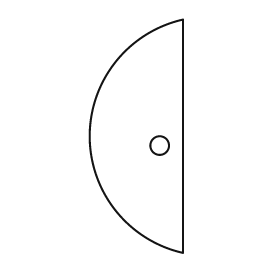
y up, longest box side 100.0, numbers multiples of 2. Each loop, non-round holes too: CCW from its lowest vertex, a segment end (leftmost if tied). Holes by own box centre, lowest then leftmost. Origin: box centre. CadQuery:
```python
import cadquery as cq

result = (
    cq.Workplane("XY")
    .moveTo(20.0, -50.0)
    .lineTo(20.0, 50.0)
    .threePointArc((-20.0, 0.0), (20.0, -50.0))
    .close()
    .moveTo(10.0, -4.0)
    .circle(4.0)
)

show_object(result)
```